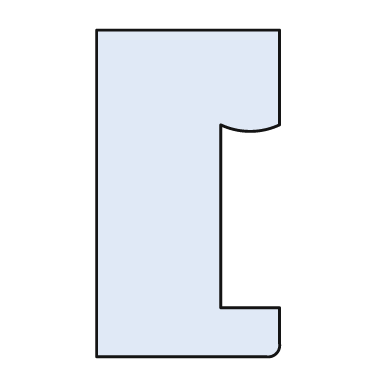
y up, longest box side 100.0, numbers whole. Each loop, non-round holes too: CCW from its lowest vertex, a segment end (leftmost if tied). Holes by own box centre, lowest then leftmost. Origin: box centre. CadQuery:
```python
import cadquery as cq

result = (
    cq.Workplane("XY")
    .moveTo(-28.0, -50.0)
    .lineTo(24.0, -50.0)
    .threePointArc((27.0, -49.0), (28.0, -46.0))
    .lineTo(28.0, -35.0)
    .lineTo(10.0, -35.0)
    .lineTo(10.0, 21.0)
    .threePointArc((19.0, 19.0), (28.0, 21.0))
    .lineTo(28.0, 50.0)
    .lineTo(-28.0, 50.0)
    .close()
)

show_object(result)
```